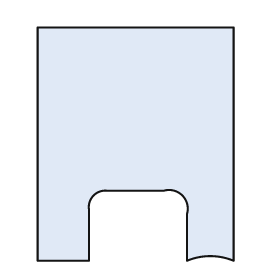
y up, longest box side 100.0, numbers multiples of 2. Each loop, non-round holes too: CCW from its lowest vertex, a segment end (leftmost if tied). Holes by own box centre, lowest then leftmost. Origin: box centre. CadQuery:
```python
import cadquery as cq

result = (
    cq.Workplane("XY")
    .moveTo(-42.0, -50.0)
    .lineTo(-20.0, -50.0)
    .lineTo(-20.0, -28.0)
    .threePointArc((-18.0, -22.0), (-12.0, -20.0))
    .lineTo(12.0, -20.0)
    .threePointArc((20.0, -22.0), (22.0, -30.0))
    .lineTo(22.0, -50.0)
    .threePointArc((32.0, -48.0), (42.0, -50.0))
    .lineTo(42.0, 50.0)
    .lineTo(-42.0, 50.0)
    .close()
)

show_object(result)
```